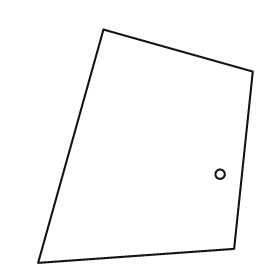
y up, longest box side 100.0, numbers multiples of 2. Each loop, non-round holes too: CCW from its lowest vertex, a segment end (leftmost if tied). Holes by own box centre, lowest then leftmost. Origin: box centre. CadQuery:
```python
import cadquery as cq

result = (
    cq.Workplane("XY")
    .moveTo(-46.0, -50.0)
    .lineTo(38.0, -44.0)
    .lineTo(46.0, 32.0)
    .lineTo(-18.0, 50.0)
    .close()
    .moveTo(32.0, -12.0)
    .circle(2.0)
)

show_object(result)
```